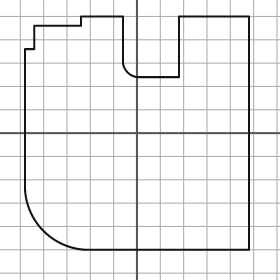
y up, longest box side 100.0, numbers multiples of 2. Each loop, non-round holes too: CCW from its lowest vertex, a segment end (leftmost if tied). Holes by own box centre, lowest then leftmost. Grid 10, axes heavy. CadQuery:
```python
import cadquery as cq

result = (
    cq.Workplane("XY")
    .moveTo(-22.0, -50.0)
    .lineTo(48.0, -50.0)
    .lineTo(48.0, 50.0)
    .lineTo(18.0, 50.0)
    .lineTo(18.0, 24.0)
    .lineTo(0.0, 24.0)
    .threePointArc((-4.0, 26.0), (-6.0, 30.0))
    .lineTo(-6.0, 50.0)
    .lineTo(-24.0, 50.0)
    .lineTo(-24.0, 46.0)
    .lineTo(-44.0, 46.0)
    .lineTo(-44.0, 36.0)
    .lineTo(-48.0, 36.0)
    .lineTo(-48.0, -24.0)
    .threePointArc((-40.0, -42.0), (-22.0, -50.0))
    .close()
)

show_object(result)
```